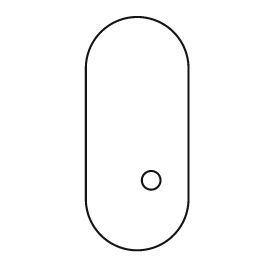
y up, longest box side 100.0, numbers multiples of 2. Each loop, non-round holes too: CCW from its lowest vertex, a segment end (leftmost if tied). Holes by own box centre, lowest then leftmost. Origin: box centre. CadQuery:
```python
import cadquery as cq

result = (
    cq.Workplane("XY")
    .moveTo(-22.0, -28.0)
    .threePointArc((0.0, -50.0), (22.0, -28.0))
    .lineTo(22.0, 28.0)
    .threePointArc((0.0, 50.0), (-22.0, 28.0))
    .close()
    .moveTo(6.0, -20.0)
    .circle(4.0)
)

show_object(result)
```